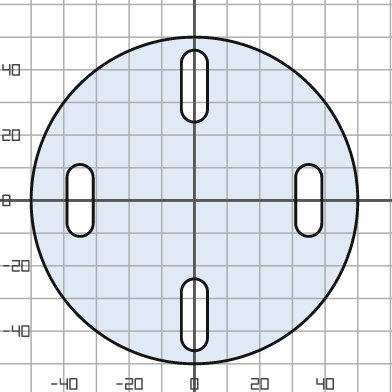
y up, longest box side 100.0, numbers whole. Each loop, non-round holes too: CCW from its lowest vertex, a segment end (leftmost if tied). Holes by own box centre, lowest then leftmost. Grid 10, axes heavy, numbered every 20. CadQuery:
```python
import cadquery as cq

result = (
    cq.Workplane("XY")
    .moveTo(0.0, 0.0)
    .circle(50.0)
    .moveTo(-4.0, -42.0)
    .threePointArc((0.0, -46.0), (4.0, -42.0))
    .lineTo(4.0, -28.0)
    .threePointArc((0.0, -24.0), (-4.0, -28.0))
    .close()
    .moveTo(-39.0, -7.0)
    .threePointArc((-35.0, -11.0), (-31.0, -7.0))
    .lineTo(-31.0, 7.0)
    .threePointArc((-35.0, 11.0), (-39.0, 7.0))
    .close()
    .moveTo(31.0, -7.0)
    .threePointArc((35.0, -11.0), (39.0, -7.0))
    .lineTo(39.0, 7.0)
    .threePointArc((35.0, 11.0), (31.0, 7.0))
    .close()
    .moveTo(-4.0, 28.0)
    .threePointArc((0.0, 24.0), (4.0, 28.0))
    .lineTo(4.0, 42.0)
    .threePointArc((0.0, 46.0), (-4.0, 42.0))
    .close()
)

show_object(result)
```